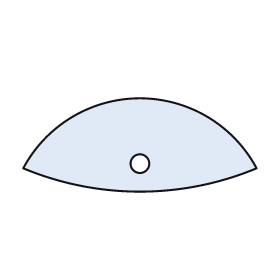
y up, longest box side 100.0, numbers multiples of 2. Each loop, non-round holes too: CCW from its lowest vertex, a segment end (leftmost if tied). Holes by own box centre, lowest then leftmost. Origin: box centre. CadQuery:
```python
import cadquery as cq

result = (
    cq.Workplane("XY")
    .moveTo(-50.0, -10.0)
    .threePointArc((0.0, -20.0), (50.0, -10.0))
    .threePointArc((0.0, 20.0), (-50.0, -10.0))
    .close()
    .moveTo(0.0, -8.0)
    .circle(4.0)
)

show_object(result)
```